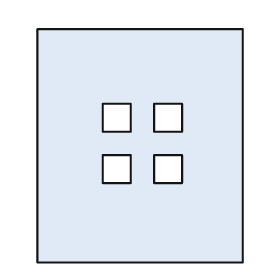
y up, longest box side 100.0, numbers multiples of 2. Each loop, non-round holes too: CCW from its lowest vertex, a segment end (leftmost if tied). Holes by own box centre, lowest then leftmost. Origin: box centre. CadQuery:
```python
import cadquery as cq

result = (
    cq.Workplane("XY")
    .moveTo(-44.0, -50.0)
    .lineTo(44.0, -50.0)
    .lineTo(44.0, 50.0)
    .lineTo(-44.0, 50.0)
    .close()
    .moveTo(-16.0, -16.0)
    .lineTo(-4.0, -16.0)
    .lineTo(-4.0, -4.0)
    .lineTo(-16.0, -4.0)
    .close()
    .moveTo(6.0, -16.0)
    .lineTo(18.0, -16.0)
    .lineTo(18.0, -4.0)
    .lineTo(6.0, -4.0)
    .close()
    .moveTo(-16.0, 6.0)
    .lineTo(-4.0, 6.0)
    .lineTo(-4.0, 18.0)
    .lineTo(-16.0, 18.0)
    .close()
    .moveTo(6.0, 6.0)
    .lineTo(18.0, 6.0)
    .lineTo(18.0, 18.0)
    .lineTo(6.0, 18.0)
    .close()
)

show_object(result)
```